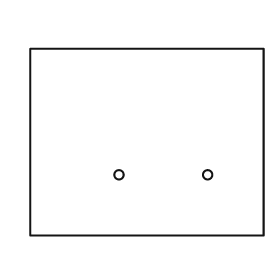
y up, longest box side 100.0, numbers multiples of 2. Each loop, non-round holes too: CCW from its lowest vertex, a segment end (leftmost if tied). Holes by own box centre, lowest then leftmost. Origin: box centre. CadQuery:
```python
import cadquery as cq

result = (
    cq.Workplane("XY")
    .moveTo(-50.0, -40.0)
    .lineTo(50.0, -40.0)
    .lineTo(50.0, 40.0)
    .lineTo(-50.0, 40.0)
    .close()
    .moveTo(-12.0, -14.0)
    .circle(2.0)
    .moveTo(26.0, -14.0)
    .circle(2.0)
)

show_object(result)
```